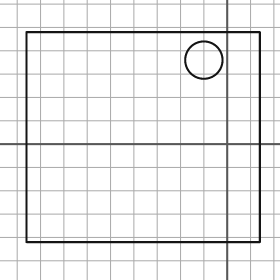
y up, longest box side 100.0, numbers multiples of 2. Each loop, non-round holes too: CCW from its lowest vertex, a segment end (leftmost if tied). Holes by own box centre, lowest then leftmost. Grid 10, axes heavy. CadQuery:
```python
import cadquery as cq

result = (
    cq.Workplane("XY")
    .moveTo(-86.0, -42.0)
    .lineTo(14.0, -42.0)
    .lineTo(14.0, 48.0)
    .lineTo(-86.0, 48.0)
    .close()
    .moveTo(-10.0, 36.0)
    .circle(8.0)
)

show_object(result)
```